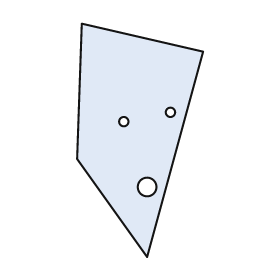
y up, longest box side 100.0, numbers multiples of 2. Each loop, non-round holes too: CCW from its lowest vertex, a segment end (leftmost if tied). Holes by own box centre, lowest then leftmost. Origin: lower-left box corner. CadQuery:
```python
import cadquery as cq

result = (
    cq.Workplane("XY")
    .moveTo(30.0, 0.0)
    .lineTo(54.0, 88.0)
    .lineTo(2.0, 100.0)
    .lineTo(0.0, 42.0)
    .close()
    .moveTo(30.0, 30.0)
    .circle(4.0)
    .moveTo(20.0, 58.0)
    .circle(2.0)
    .moveTo(40.0, 62.0)
    .circle(2.0)
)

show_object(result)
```